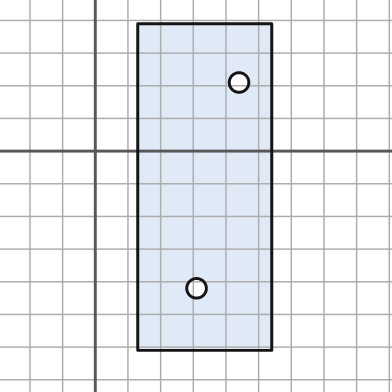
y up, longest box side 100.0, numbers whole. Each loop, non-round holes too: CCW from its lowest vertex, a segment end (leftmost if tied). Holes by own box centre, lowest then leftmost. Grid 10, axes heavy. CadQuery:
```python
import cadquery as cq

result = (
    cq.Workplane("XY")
    .moveTo(13.0, -61.0)
    .lineTo(54.0, -61.0)
    .lineTo(54.0, 39.0)
    .lineTo(13.0, 39.0)
    .close()
    .moveTo(31.0, -42.0)
    .circle(3.0)
    .moveTo(44.0, 21.0)
    .circle(3.0)
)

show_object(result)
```